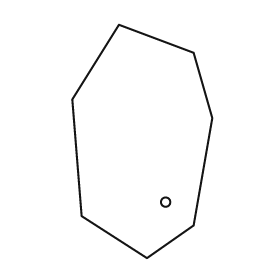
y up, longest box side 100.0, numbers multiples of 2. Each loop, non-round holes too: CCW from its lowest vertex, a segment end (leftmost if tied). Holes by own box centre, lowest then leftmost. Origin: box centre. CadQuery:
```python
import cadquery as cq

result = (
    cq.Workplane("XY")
    .moveTo(2.0, -50.0)
    .lineTo(22.0, -36.0)
    .lineTo(30.0, 10.0)
    .lineTo(22.0, 38.0)
    .lineTo(-10.0, 50.0)
    .lineTo(-30.0, 18.0)
    .lineTo(-26.0, -32.0)
    .close()
    .moveTo(10.0, -26.0)
    .circle(2.0)
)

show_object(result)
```